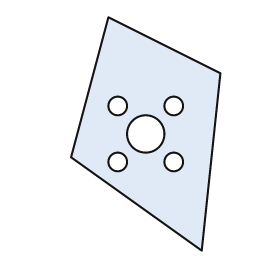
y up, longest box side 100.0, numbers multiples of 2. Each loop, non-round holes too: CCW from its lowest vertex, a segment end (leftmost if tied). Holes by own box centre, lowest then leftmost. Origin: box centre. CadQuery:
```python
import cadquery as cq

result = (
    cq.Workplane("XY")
    .moveTo(24.0, -50.0)
    .lineTo(32.0, 26.0)
    .lineTo(-16.0, 50.0)
    .lineTo(-32.0, -10.0)
    .close()
    .moveTo(-12.0, -12.0)
    .circle(4.0)
    .moveTo(12.0, -12.0)
    .circle(4.0)
    .moveTo(0.0, 0.0)
    .circle(8.0)
    .moveTo(-12.0, 12.0)
    .circle(4.0)
    .moveTo(12.0, 12.0)
    .circle(4.0)
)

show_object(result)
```